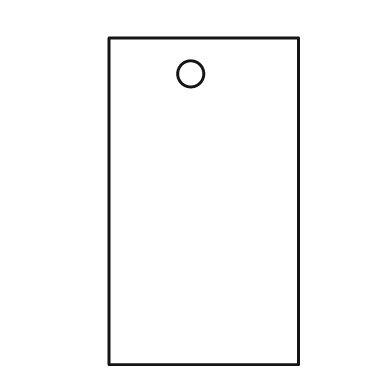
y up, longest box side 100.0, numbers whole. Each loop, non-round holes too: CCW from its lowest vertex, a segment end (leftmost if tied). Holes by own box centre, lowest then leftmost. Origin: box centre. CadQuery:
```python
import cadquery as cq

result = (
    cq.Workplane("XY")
    .moveTo(-29.0, -50.0)
    .lineTo(29.0, -50.0)
    .lineTo(29.0, 50.0)
    .lineTo(-29.0, 50.0)
    .close()
    .moveTo(-4.0, 39.0)
    .circle(4.0)
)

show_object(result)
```